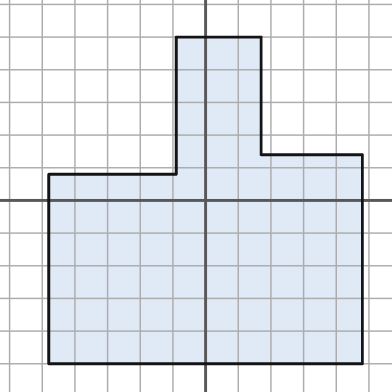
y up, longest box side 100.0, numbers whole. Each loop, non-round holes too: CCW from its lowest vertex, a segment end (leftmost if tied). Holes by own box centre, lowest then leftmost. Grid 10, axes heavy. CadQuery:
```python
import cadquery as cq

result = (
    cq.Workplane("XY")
    .moveTo(-48.0, -50.0)
    .lineTo(48.0, -50.0)
    .lineTo(48.0, 14.0)
    .lineTo(17.0, 14.0)
    .lineTo(17.0, 50.0)
    .lineTo(-9.0, 50.0)
    .lineTo(-9.0, 8.0)
    .lineTo(-48.0, 8.0)
    .close()
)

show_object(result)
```